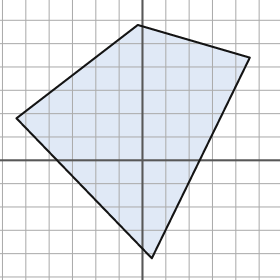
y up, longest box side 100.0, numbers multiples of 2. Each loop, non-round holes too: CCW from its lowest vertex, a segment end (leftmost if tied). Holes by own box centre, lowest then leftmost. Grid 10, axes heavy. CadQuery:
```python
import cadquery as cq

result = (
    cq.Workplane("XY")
    .moveTo(4.0, -42.0)
    .lineTo(46.0, 44.0)
    .lineTo(-2.0, 58.0)
    .lineTo(-54.0, 18.0)
    .close()
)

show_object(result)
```